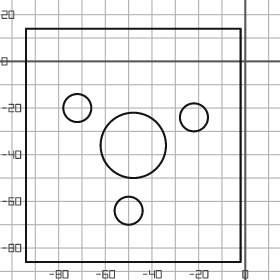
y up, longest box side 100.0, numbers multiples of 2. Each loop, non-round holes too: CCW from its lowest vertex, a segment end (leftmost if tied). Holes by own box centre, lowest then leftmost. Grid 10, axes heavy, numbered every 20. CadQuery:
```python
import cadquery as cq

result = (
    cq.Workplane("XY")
    .moveTo(-94.0, -86.0)
    .lineTo(-2.0, -86.0)
    .lineTo(-2.0, 14.0)
    .lineTo(-94.0, 14.0)
    .close()
    .moveTo(-50.0, -64.0)
    .circle(6.0)
    .moveTo(-48.0, -36.0)
    .circle(14.0)
    .moveTo(-22.0, -24.0)
    .circle(6.0)
    .moveTo(-72.0, -20.0)
    .circle(6.0)
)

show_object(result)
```